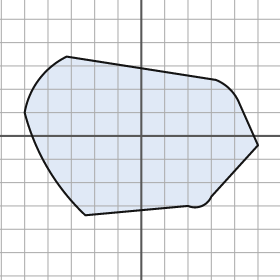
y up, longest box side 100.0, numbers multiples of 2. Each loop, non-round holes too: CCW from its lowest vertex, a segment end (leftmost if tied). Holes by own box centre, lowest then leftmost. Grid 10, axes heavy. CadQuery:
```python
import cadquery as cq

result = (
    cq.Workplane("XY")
    .moveTo(-24.0, -34.0)
    .lineTo(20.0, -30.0)
    .threePointArc((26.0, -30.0), (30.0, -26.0))
    .lineTo(50.0, -4.0)
    .lineTo(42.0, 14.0)
    .threePointArc((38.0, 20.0), (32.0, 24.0))
    .lineTo(-32.0, 34.0)
    .threePointArc((-44.0, 24.0), (-50.0, 10.0))
    .threePointArc((-40.0, -14.0), (-24.0, -34.0))
    .close()
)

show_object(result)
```